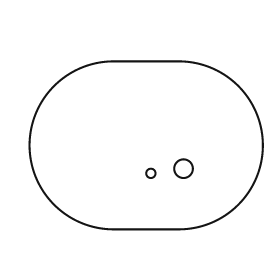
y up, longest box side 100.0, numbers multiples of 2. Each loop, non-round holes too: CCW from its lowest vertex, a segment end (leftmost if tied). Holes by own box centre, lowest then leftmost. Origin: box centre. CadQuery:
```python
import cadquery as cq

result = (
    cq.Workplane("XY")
    .moveTo(-14.0, -36.0)
    .lineTo(14.0, -36.0)
    .threePointArc((50.0, 0.0), (14.0, 36.0))
    .lineTo(-14.0, 36.0)
    .threePointArc((-50.0, 0.0), (-14.0, -36.0))
    .close()
    .moveTo(2.0, -12.0)
    .circle(2.0)
    .moveTo(16.0, -10.0)
    .circle(4.0)
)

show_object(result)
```